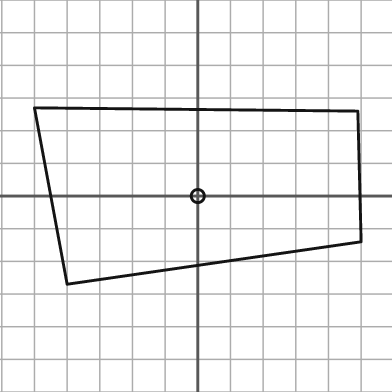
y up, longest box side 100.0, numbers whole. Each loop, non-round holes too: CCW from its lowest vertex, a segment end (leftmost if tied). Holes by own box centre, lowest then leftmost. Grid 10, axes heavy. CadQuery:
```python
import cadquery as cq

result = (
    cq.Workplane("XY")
    .moveTo(-40.0, -27.0)
    .lineTo(50.0, -14.0)
    .lineTo(49.0, 26.0)
    .lineTo(-50.0, 27.0)
    .close()
    .moveTo(0.0, 0.0)
    .circle(2.0)
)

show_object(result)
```